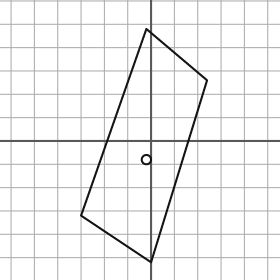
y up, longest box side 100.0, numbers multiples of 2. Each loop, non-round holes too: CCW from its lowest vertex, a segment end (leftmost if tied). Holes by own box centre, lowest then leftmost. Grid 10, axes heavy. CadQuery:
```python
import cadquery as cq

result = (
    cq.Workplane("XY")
    .moveTo(0.0, -52.0)
    .lineTo(24.0, 26.0)
    .lineTo(-2.0, 48.0)
    .lineTo(-30.0, -32.0)
    .close()
    .moveTo(-2.0, -8.0)
    .circle(2.0)
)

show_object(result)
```